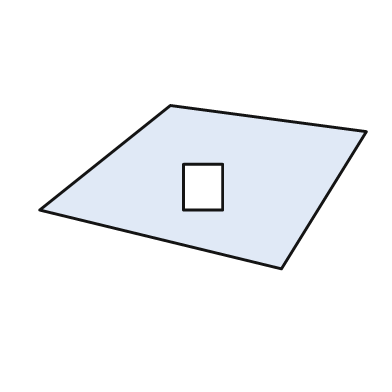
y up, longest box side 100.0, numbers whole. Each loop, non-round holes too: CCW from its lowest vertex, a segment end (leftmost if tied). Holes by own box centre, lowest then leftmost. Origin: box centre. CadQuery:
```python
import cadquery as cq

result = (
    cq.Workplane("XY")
    .moveTo(24.0, -25.0)
    .lineTo(50.0, 17.0)
    .lineTo(-10.0, 25.0)
    .lineTo(-50.0, -7.0)
    .close()
    .moveTo(-6.0, -7.0)
    .lineTo(6.0, -7.0)
    .lineTo(6.0, 7.0)
    .lineTo(-6.0, 7.0)
    .close()
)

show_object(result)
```